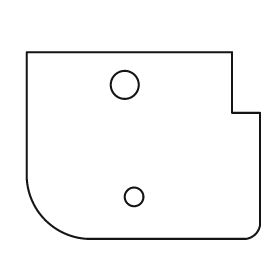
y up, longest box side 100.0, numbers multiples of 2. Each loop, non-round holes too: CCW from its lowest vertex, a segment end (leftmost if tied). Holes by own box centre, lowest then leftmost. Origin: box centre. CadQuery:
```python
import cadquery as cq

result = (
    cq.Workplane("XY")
    .moveTo(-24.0, -40.0)
    .lineTo(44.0, -40.0)
    .threePointArc((48.0, -38.0), (50.0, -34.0))
    .lineTo(50.0, 14.0)
    .lineTo(38.0, 14.0)
    .lineTo(38.0, 40.0)
    .lineTo(-50.0, 40.0)
    .lineTo(-50.0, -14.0)
    .threePointArc((-42.0, -32.0), (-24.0, -40.0))
    .close()
    .moveTo(-4.0, -22.0)
    .circle(4.0)
    .moveTo(-8.0, 26.0)
    .circle(6.0)
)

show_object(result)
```